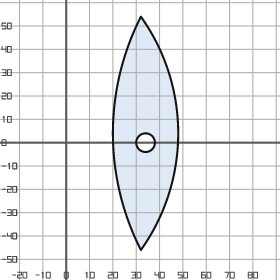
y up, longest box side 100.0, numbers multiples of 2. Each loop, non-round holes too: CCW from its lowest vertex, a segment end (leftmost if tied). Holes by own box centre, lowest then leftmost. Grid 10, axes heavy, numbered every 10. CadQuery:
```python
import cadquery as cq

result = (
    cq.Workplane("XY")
    .moveTo(32.0, -46.0)
    .threePointArc((48.0, 4.0), (32.0, 54.0))
    .threePointArc((20.0, 4.0), (32.0, -46.0))
    .close()
    .moveTo(34.0, 0.0)
    .circle(4.0)
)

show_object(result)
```